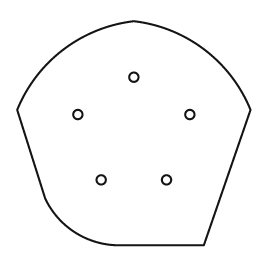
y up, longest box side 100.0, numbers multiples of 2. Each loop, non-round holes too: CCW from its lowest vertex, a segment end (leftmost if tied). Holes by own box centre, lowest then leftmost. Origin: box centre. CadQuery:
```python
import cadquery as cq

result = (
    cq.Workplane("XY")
    .moveTo(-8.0, -48.0)
    .lineTo(30.0, -48.0)
    .lineTo(50.0, 10.0)
    .threePointArc((30.0, 36.0), (0.0, 48.0))
    .threePointArc((-30.0, 36.0), (-50.0, 10.0))
    .lineTo(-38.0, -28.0)
    .threePointArc((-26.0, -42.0), (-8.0, -48.0))
    .close()
    .moveTo(-14.0, -20.0)
    .circle(2.0)
    .moveTo(14.0, -20.0)
    .circle(2.0)
    .moveTo(-24.0, 8.0)
    .circle(2.0)
    .moveTo(24.0, 8.0)
    .circle(2.0)
    .moveTo(0.0, 24.0)
    .circle(2.0)
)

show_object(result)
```